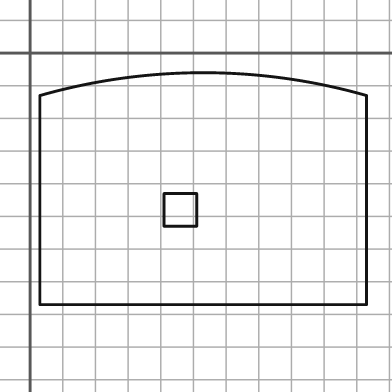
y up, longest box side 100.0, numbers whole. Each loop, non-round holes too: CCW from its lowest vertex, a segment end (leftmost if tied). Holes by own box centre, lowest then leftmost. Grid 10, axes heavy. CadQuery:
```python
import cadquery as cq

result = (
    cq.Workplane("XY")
    .moveTo(3.0, -77.0)
    .lineTo(103.0, -77.0)
    .lineTo(103.0, -13.0)
    .threePointArc((53.0, -6.0), (3.0, -13.0))
    .close()
    .moveTo(41.0, -53.0)
    .lineTo(51.0, -53.0)
    .lineTo(51.0, -43.0)
    .lineTo(41.0, -43.0)
    .close()
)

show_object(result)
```